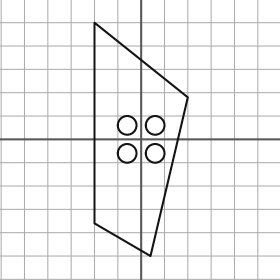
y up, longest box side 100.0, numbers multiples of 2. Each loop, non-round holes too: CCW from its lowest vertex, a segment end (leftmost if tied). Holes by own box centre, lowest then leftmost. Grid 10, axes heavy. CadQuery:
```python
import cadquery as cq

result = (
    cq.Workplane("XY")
    .moveTo(4.0, -50.0)
    .lineTo(20.0, 18.0)
    .lineTo(-20.0, 50.0)
    .lineTo(-20.0, -36.0)
    .close()
    .moveTo(-6.0, -6.0)
    .circle(4.0)
    .moveTo(6.0, -6.0)
    .circle(4.0)
    .moveTo(-6.0, 6.0)
    .circle(4.0)
    .moveTo(6.0, 6.0)
    .circle(4.0)
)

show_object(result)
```